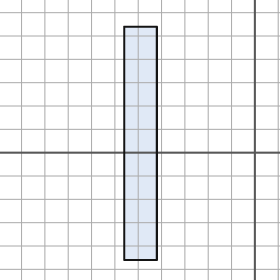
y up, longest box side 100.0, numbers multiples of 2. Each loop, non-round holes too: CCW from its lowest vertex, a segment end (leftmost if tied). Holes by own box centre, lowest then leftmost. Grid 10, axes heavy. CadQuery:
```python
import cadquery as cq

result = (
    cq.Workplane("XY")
    .moveTo(-56.0, -46.0)
    .lineTo(-42.0, -46.0)
    .lineTo(-42.0, 54.0)
    .lineTo(-56.0, 54.0)
    .close()
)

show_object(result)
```